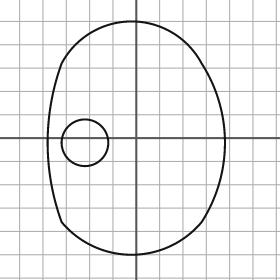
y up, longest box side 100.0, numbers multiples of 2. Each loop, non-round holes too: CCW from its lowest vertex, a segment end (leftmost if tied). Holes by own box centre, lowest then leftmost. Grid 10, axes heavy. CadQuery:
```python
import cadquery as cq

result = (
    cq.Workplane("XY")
    .moveTo(-32.0, -36.0)
    .threePointArc((-2.0, -50.0), (28.0, -36.0))
    .threePointArc((38.0, -2.0), (28.0, 32.0))
    .threePointArc((-2.0, 50.0), (-32.0, 32.0))
    .threePointArc((-38.0, -2.0), (-32.0, -36.0))
    .close()
    .moveTo(-22.0, -2.0)
    .circle(10.0)
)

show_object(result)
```